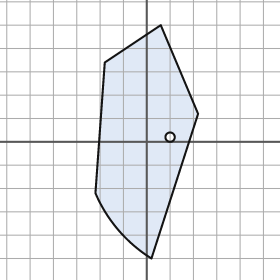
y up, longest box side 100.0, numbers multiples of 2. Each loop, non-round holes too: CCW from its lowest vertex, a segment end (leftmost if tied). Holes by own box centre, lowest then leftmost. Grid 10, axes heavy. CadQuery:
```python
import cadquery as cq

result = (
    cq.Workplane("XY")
    .moveTo(2.0, -50.0)
    .lineTo(22.0, 12.0)
    .lineTo(6.0, 50.0)
    .lineTo(-18.0, 34.0)
    .lineTo(-22.0, -22.0)
    .threePointArc((-12.0, -38.0), (2.0, -50.0))
    .close()
    .moveTo(10.0, 2.0)
    .circle(2.0)
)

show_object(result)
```